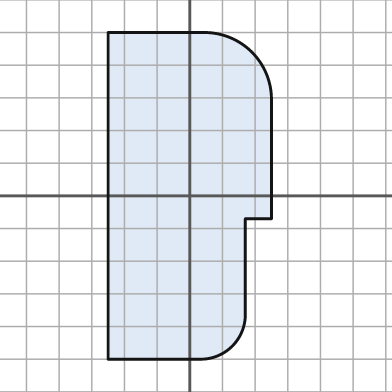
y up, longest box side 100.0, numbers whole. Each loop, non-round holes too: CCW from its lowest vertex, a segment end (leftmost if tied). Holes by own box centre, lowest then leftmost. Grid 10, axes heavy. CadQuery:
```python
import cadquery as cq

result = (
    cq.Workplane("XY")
    .moveTo(-25.0, -50.0)
    .lineTo(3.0, -50.0)
    .threePointArc((13.0, -46.0), (17.0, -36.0))
    .lineTo(17.0, -7.0)
    .lineTo(25.0, -7.0)
    .lineTo(25.0, 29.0)
    .threePointArc((19.0, 44.0), (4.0, 50.0))
    .lineTo(-25.0, 50.0)
    .close()
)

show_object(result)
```